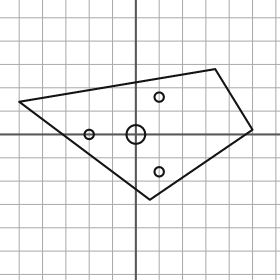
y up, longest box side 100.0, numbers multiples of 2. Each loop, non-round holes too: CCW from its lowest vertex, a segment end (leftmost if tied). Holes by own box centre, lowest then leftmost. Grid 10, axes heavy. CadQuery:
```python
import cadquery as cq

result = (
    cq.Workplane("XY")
    .moveTo(6.0, -28.0)
    .lineTo(50.0, 2.0)
    .lineTo(34.0, 28.0)
    .lineTo(-50.0, 14.0)
    .close()
    .moveTo(10.0, -16.0)
    .circle(2.0)
    .moveTo(-20.0, 0.0)
    .circle(2.0)
    .moveTo(0.0, 0.0)
    .circle(4.0)
    .moveTo(10.0, 16.0)
    .circle(2.0)
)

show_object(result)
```